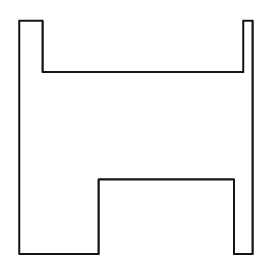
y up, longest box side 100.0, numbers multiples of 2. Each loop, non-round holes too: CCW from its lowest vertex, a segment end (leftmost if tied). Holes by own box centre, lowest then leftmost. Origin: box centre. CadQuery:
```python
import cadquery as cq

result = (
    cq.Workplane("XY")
    .moveTo(-50.0, -50.0)
    .lineTo(-16.0, -50.0)
    .lineTo(-16.0, -18.0)
    .lineTo(42.0, -18.0)
    .lineTo(42.0, -50.0)
    .lineTo(50.0, -50.0)
    .lineTo(50.0, 50.0)
    .lineTo(46.0, 50.0)
    .lineTo(46.0, 28.0)
    .lineTo(-40.0, 28.0)
    .lineTo(-40.0, 50.0)
    .lineTo(-50.0, 50.0)
    .close()
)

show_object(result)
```